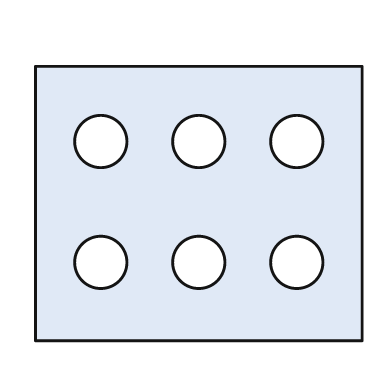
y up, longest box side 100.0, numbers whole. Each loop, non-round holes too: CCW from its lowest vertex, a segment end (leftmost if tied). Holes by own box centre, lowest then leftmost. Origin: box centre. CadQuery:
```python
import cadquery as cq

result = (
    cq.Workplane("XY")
    .moveTo(-50.0, -42.0)
    .lineTo(50.0, -42.0)
    .lineTo(50.0, 42.0)
    .lineTo(-50.0, 42.0)
    .close()
    .moveTo(-30.0, -18.0)
    .circle(8.0)
    .moveTo(0.0, -18.0)
    .circle(8.0)
    .moveTo(30.0, -18.0)
    .circle(8.0)
    .moveTo(-30.0, 19.0)
    .circle(8.0)
    .moveTo(0.0, 19.0)
    .circle(8.0)
    .moveTo(30.0, 19.0)
    .circle(8.0)
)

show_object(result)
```